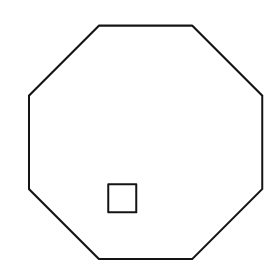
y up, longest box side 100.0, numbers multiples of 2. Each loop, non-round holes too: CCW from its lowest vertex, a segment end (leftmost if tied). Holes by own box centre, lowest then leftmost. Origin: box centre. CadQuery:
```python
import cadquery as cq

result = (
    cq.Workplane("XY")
    .moveTo(-20.0, -50.0)
    .lineTo(20.0, -50.0)
    .lineTo(50.0, -20.0)
    .lineTo(50.0, 20.0)
    .lineTo(20.0, 50.0)
    .lineTo(-20.0, 50.0)
    .lineTo(-50.0, 20.0)
    .lineTo(-50.0, -20.0)
    .close()
    .moveTo(-16.0, -30.0)
    .lineTo(-4.0, -30.0)
    .lineTo(-4.0, -18.0)
    .lineTo(-16.0, -18.0)
    .close()
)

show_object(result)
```